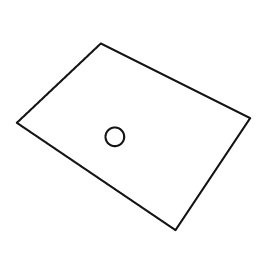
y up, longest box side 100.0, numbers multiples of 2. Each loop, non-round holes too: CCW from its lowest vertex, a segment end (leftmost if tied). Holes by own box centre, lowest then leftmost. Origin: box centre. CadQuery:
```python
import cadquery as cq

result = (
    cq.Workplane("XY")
    .moveTo(18.0, -40.0)
    .lineTo(50.0, 8.0)
    .lineTo(-14.0, 40.0)
    .lineTo(-50.0, 6.0)
    .close()
    .moveTo(-8.0, 0.0)
    .circle(4.0)
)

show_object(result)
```